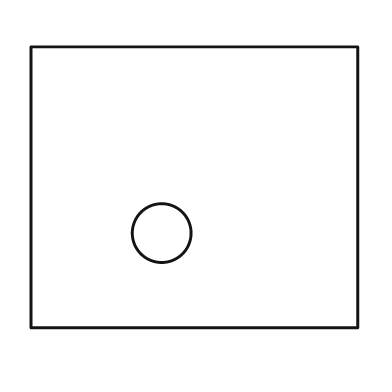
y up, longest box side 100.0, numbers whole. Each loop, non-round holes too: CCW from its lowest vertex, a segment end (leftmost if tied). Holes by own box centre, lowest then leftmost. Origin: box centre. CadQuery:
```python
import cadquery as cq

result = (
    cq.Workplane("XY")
    .moveTo(-50.0, -43.0)
    .lineTo(50.0, -43.0)
    .lineTo(50.0, 43.0)
    .lineTo(-50.0, 43.0)
    .close()
    .moveTo(-10.0, -14.0)
    .circle(9.0)
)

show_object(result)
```